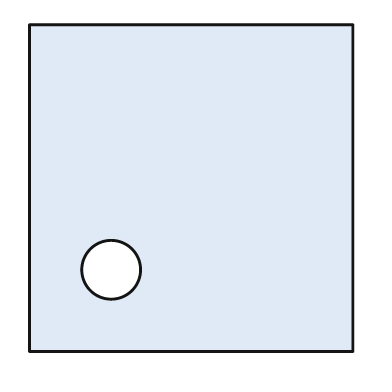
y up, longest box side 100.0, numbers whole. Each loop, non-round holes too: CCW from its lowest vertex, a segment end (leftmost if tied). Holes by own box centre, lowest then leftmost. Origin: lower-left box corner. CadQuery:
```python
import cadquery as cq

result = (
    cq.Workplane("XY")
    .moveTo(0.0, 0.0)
    .lineTo(99.0, 0.0)
    .lineTo(99.0, 100.0)
    .lineTo(0.0, 100.0)
    .close()
    .moveTo(25.0, 25.0)
    .circle(9.0)
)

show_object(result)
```